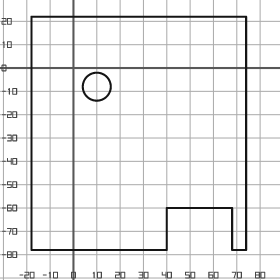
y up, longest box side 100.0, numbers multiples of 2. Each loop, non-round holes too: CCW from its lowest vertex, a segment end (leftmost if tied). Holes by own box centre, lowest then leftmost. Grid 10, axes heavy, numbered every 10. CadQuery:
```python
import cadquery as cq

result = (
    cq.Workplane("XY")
    .moveTo(-18.0, -78.0)
    .lineTo(40.0, -78.0)
    .lineTo(40.0, -60.0)
    .lineTo(68.0, -60.0)
    .lineTo(68.0, -78.0)
    .lineTo(74.0, -78.0)
    .lineTo(74.0, 22.0)
    .lineTo(-18.0, 22.0)
    .close()
    .moveTo(10.0, -8.0)
    .circle(6.0)
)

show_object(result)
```